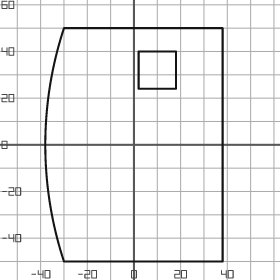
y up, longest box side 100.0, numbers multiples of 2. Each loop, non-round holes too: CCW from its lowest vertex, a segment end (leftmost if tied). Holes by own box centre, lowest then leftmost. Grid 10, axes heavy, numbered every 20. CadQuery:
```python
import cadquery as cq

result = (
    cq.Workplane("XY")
    .moveTo(-30.0, -50.0)
    .lineTo(38.0, -50.0)
    .lineTo(38.0, 50.0)
    .lineTo(-30.0, 50.0)
    .threePointArc((-38.0, 0.0), (-30.0, -50.0))
    .close()
    .moveTo(2.0, 24.0)
    .lineTo(18.0, 24.0)
    .lineTo(18.0, 40.0)
    .lineTo(2.0, 40.0)
    .close()
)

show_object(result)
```